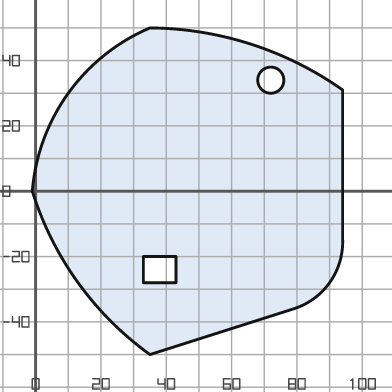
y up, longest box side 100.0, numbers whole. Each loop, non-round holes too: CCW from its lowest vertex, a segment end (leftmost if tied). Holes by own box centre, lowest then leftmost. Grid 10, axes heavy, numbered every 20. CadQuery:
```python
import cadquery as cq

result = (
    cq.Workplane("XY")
    .moveTo(35.0, -50.0)
    .lineTo(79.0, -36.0)
    .threePointArc((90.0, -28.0), (94.0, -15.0))
    .lineTo(94.0, 31.0)
    .threePointArc((66.0, 45.0), (35.0, 50.0))
    .threePointArc((10.0, 30.0), (-1.0, 0.0))
    .threePointArc((13.0, -28.0), (35.0, -50.0))
    .close()
    .moveTo(33.0, -28.0)
    .lineTo(43.0, -28.0)
    .lineTo(43.0, -20.0)
    .lineTo(33.0, -20.0)
    .close()
    .moveTo(72.0, 34.0)
    .circle(4.0)
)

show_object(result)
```